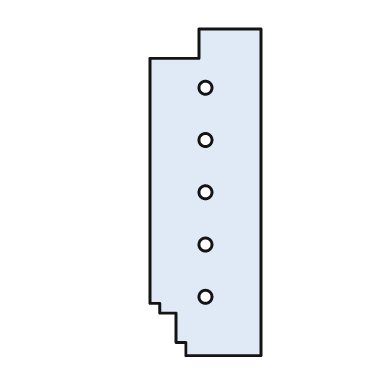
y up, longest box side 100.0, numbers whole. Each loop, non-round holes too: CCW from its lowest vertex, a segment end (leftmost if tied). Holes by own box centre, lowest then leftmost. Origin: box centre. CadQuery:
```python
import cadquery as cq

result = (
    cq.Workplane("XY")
    .moveTo(-6.0, -50.0)
    .lineTo(17.0, -50.0)
    .lineTo(17.0, 50.0)
    .lineTo(-2.0, 50.0)
    .lineTo(-2.0, 41.0)
    .lineTo(-17.0, 41.0)
    .lineTo(-17.0, -34.0)
    .lineTo(-14.0, -34.0)
    .lineTo(-14.0, -37.0)
    .lineTo(-9.0, -37.0)
    .lineTo(-9.0, -46.0)
    .lineTo(-6.0, -46.0)
    .close()
    .moveTo(0.0, -32.0)
    .circle(2.0)
    .moveTo(0.0, -16.0)
    .circle(2.0)
    .moveTo(0.0, 0.0)
    .circle(2.0)
    .moveTo(0.0, 16.0)
    .circle(2.0)
    .moveTo(0.0, 32.0)
    .circle(2.0)
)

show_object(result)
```